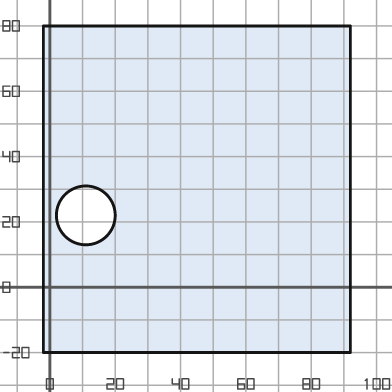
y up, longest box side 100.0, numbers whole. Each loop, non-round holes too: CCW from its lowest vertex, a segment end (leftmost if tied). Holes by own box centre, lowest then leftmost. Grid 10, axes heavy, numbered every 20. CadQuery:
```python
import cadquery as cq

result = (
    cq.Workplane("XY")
    .moveTo(-2.0, -20.0)
    .lineTo(92.0, -20.0)
    .lineTo(92.0, 80.0)
    .lineTo(-2.0, 80.0)
    .close()
    .moveTo(11.0, 22.0)
    .circle(9.0)
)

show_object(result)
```